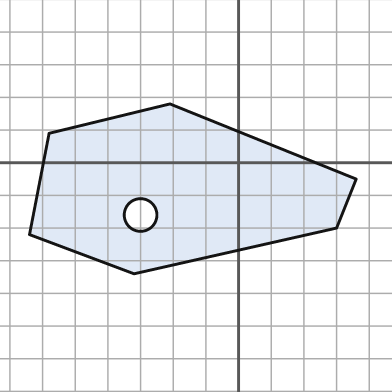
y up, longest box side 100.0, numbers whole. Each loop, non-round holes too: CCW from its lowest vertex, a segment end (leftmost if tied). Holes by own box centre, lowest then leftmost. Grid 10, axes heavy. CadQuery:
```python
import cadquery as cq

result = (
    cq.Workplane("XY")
    .moveTo(-32.0, -34.0)
    .lineTo(30.0, -20.0)
    .lineTo(36.0, -5.0)
    .lineTo(-21.0, 18.0)
    .lineTo(-58.0, 9.0)
    .lineTo(-64.0, -22.0)
    .close()
    .moveTo(-30.0, -16.0)
    .circle(5.0)
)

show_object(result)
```